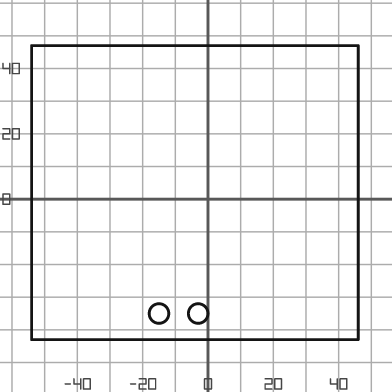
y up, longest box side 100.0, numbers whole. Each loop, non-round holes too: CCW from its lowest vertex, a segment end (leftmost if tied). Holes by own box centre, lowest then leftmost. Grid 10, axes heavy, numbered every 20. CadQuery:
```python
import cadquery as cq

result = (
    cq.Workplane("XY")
    .moveTo(-54.0, -43.0)
    .lineTo(46.0, -43.0)
    .lineTo(46.0, 47.0)
    .lineTo(-54.0, 47.0)
    .close()
    .moveTo(-15.0, -35.0)
    .circle(3.0)
    .moveTo(-3.0, -35.0)
    .circle(3.0)
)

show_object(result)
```